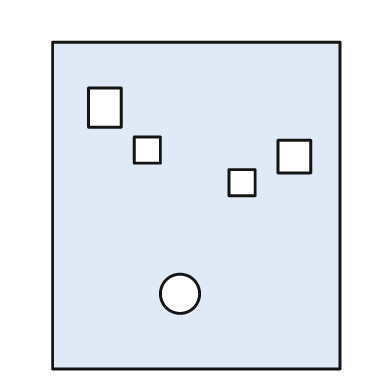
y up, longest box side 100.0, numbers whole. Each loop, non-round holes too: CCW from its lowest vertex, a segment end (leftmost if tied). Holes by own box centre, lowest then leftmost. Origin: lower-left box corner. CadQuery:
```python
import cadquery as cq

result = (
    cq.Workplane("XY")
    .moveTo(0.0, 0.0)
    .lineTo(88.0, 0.0)
    .lineTo(88.0, 100.0)
    .lineTo(0.0, 100.0)
    .close()
    .moveTo(39.0, 23.0)
    .circle(6.0)
    .moveTo(54.0, 53.0)
    .lineTo(62.0, 53.0)
    .lineTo(62.0, 61.0)
    .lineTo(54.0, 61.0)
    .close()
    .moveTo(69.0, 60.0)
    .lineTo(79.0, 60.0)
    .lineTo(79.0, 70.0)
    .lineTo(69.0, 70.0)
    .close()
    .moveTo(25.0, 63.0)
    .lineTo(33.0, 63.0)
    .lineTo(33.0, 71.0)
    .lineTo(25.0, 71.0)
    .close()
    .moveTo(11.0, 74.0)
    .lineTo(21.0, 74.0)
    .lineTo(21.0, 86.0)
    .lineTo(11.0, 86.0)
    .close()
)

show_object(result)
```